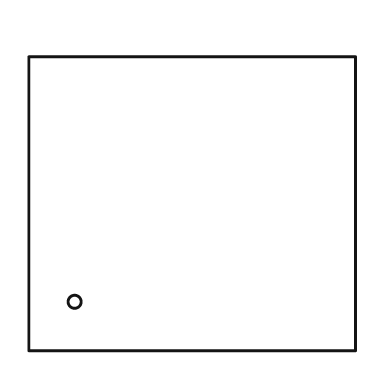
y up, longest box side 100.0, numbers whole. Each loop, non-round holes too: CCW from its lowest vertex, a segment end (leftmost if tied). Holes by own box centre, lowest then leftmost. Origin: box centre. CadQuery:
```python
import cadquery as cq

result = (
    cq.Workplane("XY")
    .moveTo(-50.0, -45.0)
    .lineTo(50.0, -45.0)
    .lineTo(50.0, 45.0)
    .lineTo(-50.0, 45.0)
    .close()
    .moveTo(-36.0, -30.0)
    .circle(2.0)
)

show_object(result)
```